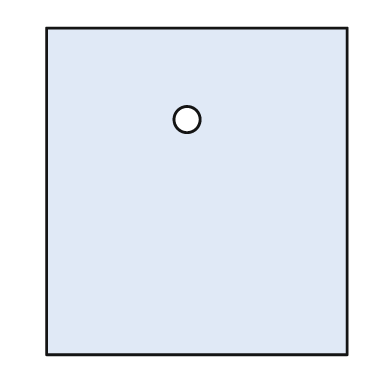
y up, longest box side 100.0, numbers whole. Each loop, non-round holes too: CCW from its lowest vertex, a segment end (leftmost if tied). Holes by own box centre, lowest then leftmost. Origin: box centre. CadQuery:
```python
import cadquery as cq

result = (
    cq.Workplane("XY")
    .moveTo(-46.0, -50.0)
    .lineTo(46.0, -50.0)
    .lineTo(46.0, 50.0)
    .lineTo(-46.0, 50.0)
    .close()
    .moveTo(-3.0, 22.0)
    .circle(4.0)
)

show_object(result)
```